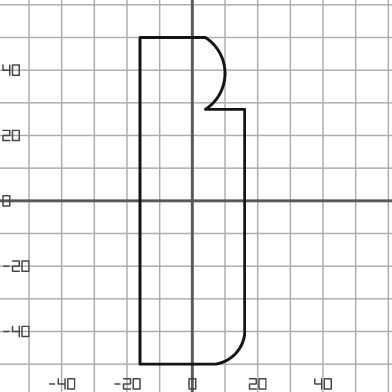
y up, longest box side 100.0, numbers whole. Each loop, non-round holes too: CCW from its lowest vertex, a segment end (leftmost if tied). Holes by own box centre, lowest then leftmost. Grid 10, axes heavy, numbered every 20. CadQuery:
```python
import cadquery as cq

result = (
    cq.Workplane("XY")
    .moveTo(-16.0, -50.0)
    .lineTo(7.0, -50.0)
    .threePointArc((13.0, -47.0), (16.0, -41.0))
    .lineTo(16.0, 28.0)
    .lineTo(4.0, 28.0)
    .threePointArc((10.0, 39.0), (4.0, 50.0))
    .lineTo(-16.0, 50.0)
    .close()
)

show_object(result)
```